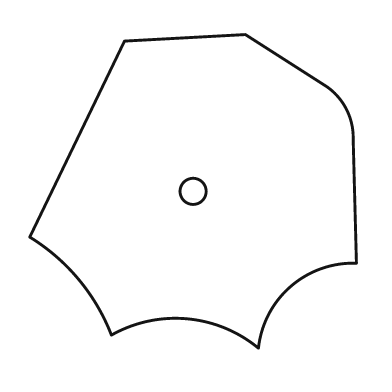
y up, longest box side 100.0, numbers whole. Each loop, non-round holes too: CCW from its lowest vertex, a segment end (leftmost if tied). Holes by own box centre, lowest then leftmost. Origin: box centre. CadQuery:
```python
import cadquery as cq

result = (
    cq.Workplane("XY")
    .moveTo(20.0, -48.0)
    .threePointArc((30.0, -29.0), (50.0, -22.0))
    .lineTo(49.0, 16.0)
    .threePointArc((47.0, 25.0), (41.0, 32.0))
    .lineTo(16.0, 48.0)
    .lineTo(-21.0, 46.0)
    .lineTo(-50.0, -14.0)
    .threePointArc((-35.0, -27.0), (-25.0, -44.0))
    .threePointArc((-2.0, -39.0), (20.0, -48.0))
    .close()
    .moveTo(0.0, 0.0)
    .circle(4.0)
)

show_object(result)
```